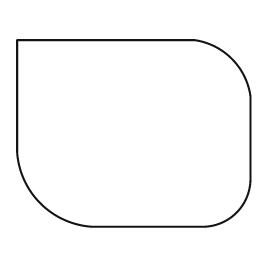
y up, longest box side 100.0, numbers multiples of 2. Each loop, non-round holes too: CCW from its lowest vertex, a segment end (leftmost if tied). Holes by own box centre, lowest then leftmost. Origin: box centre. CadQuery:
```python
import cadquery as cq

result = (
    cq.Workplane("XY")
    .moveTo(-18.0, -40.0)
    .lineTo(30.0, -40.0)
    .threePointArc((44.0, -34.0), (50.0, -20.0))
    .lineTo(50.0, 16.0)
    .threePointArc((42.0, 32.0), (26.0, 40.0))
    .lineTo(-50.0, 40.0)
    .lineTo(-50.0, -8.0)
    .threePointArc((-40.0, -30.0), (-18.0, -40.0))
    .close()
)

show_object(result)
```